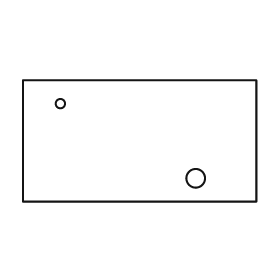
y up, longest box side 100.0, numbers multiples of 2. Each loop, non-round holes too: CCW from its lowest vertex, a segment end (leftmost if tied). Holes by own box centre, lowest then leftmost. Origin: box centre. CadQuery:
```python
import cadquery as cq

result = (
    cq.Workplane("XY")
    .moveTo(-50.0, -26.0)
    .lineTo(50.0, -26.0)
    .lineTo(50.0, 26.0)
    .lineTo(-50.0, 26.0)
    .close()
    .moveTo(24.0, -16.0)
    .circle(4.0)
    .moveTo(-34.0, 16.0)
    .circle(2.0)
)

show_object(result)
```